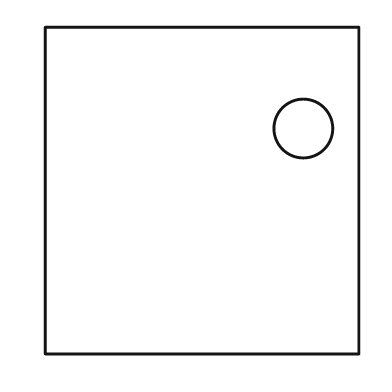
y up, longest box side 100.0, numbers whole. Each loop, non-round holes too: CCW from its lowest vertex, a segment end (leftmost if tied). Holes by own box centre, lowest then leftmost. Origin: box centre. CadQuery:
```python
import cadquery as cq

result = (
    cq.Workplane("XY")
    .moveTo(-48.0, -50.0)
    .lineTo(48.0, -50.0)
    .lineTo(48.0, 50.0)
    .lineTo(-48.0, 50.0)
    .close()
    .moveTo(31.0, 19.0)
    .circle(9.0)
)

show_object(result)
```